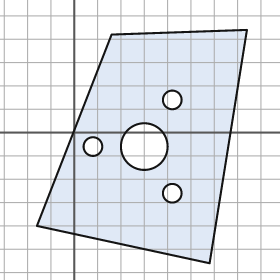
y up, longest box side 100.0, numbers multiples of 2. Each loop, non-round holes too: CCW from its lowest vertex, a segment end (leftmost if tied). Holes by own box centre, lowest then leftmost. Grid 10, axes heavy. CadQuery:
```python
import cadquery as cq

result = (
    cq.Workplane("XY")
    .moveTo(58.0, -56.0)
    .lineTo(74.0, 44.0)
    .lineTo(16.0, 42.0)
    .lineTo(-16.0, -40.0)
    .close()
    .moveTo(42.0, -26.0)
    .circle(4.0)
    .moveTo(8.0, -6.0)
    .circle(4.0)
    .moveTo(30.0, -6.0)
    .circle(10.0)
    .moveTo(42.0, 14.0)
    .circle(4.0)
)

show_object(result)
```